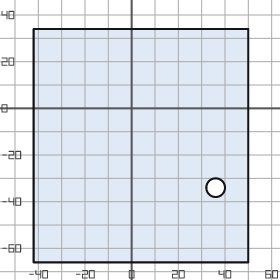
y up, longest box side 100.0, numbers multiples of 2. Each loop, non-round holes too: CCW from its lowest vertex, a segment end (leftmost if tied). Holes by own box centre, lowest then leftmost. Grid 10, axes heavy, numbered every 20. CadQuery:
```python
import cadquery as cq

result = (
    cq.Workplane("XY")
    .moveTo(-42.0, -66.0)
    .lineTo(50.0, -66.0)
    .lineTo(50.0, 34.0)
    .lineTo(-42.0, 34.0)
    .close()
    .moveTo(36.0, -34.0)
    .circle(4.0)
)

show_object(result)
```